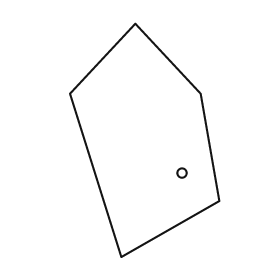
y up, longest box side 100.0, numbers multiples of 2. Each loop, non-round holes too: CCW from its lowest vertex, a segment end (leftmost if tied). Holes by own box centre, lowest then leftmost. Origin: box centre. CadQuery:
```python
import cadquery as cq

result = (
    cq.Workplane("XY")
    .moveTo(-10.0, -50.0)
    .lineTo(32.0, -26.0)
    .lineTo(24.0, 20.0)
    .lineTo(-4.0, 50.0)
    .lineTo(-32.0, 20.0)
    .close()
    .moveTo(16.0, -14.0)
    .circle(2.0)
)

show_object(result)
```